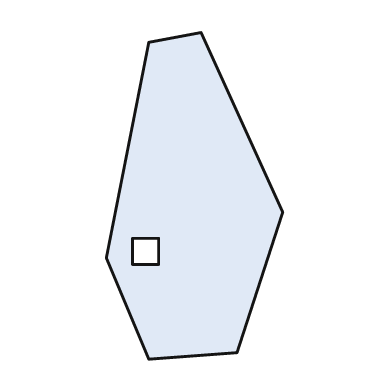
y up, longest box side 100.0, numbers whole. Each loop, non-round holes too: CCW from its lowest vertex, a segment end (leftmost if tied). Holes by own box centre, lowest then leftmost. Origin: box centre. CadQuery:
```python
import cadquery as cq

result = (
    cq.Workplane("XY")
    .moveTo(-14.0, -50.0)
    .lineTo(13.0, -48.0)
    .lineTo(27.0, -5.0)
    .lineTo(2.0, 50.0)
    .lineTo(-14.0, 47.0)
    .lineTo(-27.0, -19.0)
    .close()
    .moveTo(-19.0, -21.0)
    .lineTo(-11.0, -21.0)
    .lineTo(-11.0, -13.0)
    .lineTo(-19.0, -13.0)
    .close()
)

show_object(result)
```